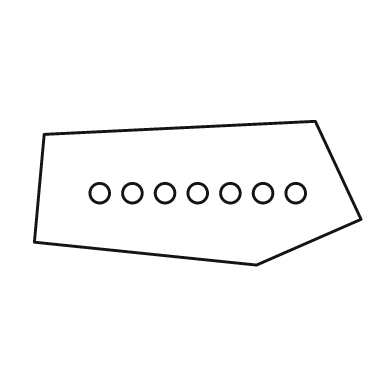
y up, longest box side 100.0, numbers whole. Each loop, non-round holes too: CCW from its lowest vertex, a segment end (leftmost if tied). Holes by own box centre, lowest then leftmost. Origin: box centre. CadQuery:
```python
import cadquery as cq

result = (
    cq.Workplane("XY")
    .moveTo(18.0, -22.0)
    .lineTo(50.0, -8.0)
    .lineTo(36.0, 22.0)
    .lineTo(-47.0, 18.0)
    .lineTo(-50.0, -15.0)
    .close()
    .moveTo(-30.0, 0.0)
    .circle(3.0)
    .moveTo(-20.0, 0.0)
    .circle(3.0)
    .moveTo(-10.0, 0.0)
    .circle(3.0)
    .moveTo(0.0, 0.0)
    .circle(3.0)
    .moveTo(10.0, 0.0)
    .circle(3.0)
    .moveTo(20.0, 0.0)
    .circle(3.0)
    .moveTo(30.0, 0.0)
    .circle(3.0)
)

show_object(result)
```